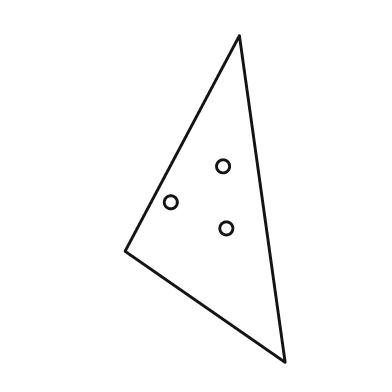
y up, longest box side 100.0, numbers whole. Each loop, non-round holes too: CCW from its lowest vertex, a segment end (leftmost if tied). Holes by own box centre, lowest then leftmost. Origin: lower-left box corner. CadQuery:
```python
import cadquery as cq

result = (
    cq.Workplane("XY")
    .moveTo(49.0, 0.0)
    .lineTo(35.0, 100.0)
    .lineTo(0.0, 34.0)
    .close()
    .moveTo(31.0, 41.0)
    .circle(2.0)
    .moveTo(14.0, 49.0)
    .circle(2.0)
    .moveTo(30.0, 60.0)
    .circle(2.0)
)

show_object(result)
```